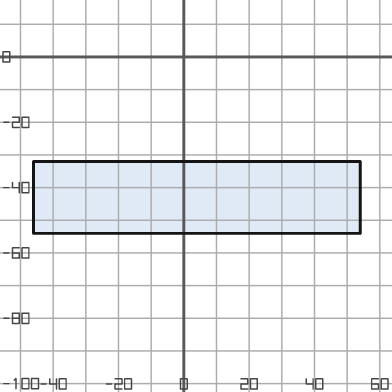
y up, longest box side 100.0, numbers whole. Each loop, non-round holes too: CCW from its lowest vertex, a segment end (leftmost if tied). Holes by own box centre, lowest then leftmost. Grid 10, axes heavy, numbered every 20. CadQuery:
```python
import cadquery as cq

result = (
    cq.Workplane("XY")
    .moveTo(-46.0, -54.0)
    .lineTo(54.0, -54.0)
    .lineTo(54.0, -32.0)
    .lineTo(-46.0, -32.0)
    .close()
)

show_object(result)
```